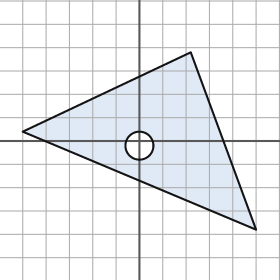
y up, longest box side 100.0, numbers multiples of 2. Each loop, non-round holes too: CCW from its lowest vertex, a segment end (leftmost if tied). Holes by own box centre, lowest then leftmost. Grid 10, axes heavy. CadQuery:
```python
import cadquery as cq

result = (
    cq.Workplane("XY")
    .moveTo(50.0, -38.0)
    .lineTo(22.0, 38.0)
    .lineTo(-50.0, 4.0)
    .close()
    .moveTo(0.0, -2.0)
    .circle(6.0)
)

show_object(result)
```